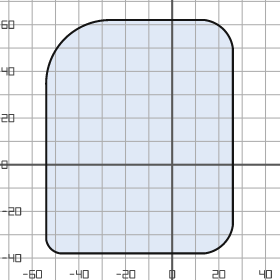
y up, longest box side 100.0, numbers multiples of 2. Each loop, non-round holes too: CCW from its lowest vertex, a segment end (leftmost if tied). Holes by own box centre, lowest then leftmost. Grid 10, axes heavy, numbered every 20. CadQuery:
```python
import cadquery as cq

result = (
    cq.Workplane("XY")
    .moveTo(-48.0, -38.0)
    .lineTo(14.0, -38.0)
    .threePointArc((22.0, -34.0), (26.0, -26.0))
    .lineTo(26.0, 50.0)
    .threePointArc((22.0, 58.0), (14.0, 62.0))
    .lineTo(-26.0, 62.0)
    .threePointArc((-46.0, 54.0), (-54.0, 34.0))
    .lineTo(-54.0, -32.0)
    .threePointArc((-52.0, -36.0), (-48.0, -38.0))
    .close()
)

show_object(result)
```